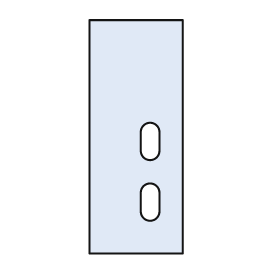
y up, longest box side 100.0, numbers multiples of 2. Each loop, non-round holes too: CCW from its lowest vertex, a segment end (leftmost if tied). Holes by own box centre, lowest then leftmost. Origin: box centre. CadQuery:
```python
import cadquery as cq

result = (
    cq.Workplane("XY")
    .moveTo(-20.0, -50.0)
    .lineTo(20.0, -50.0)
    .lineTo(20.0, 50.0)
    .lineTo(-20.0, 50.0)
    .close()
    .moveTo(2.0, -32.0)
    .threePointArc((6.0, -36.0), (10.0, -32.0))
    .lineTo(10.0, -24.0)
    .threePointArc((6.0, -20.0), (2.0, -24.0))
    .close()
    .moveTo(2.0, -6.0)
    .threePointArc((6.0, -10.0), (10.0, -6.0))
    .lineTo(10.0, 2.0)
    .threePointArc((6.0, 6.0), (2.0, 2.0))
    .close()
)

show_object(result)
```